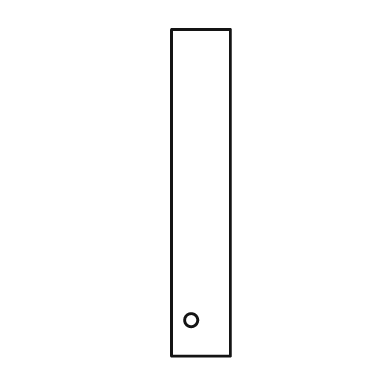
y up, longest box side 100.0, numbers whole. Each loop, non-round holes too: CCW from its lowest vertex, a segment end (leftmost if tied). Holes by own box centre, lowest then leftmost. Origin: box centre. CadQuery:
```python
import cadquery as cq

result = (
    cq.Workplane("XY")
    .moveTo(-9.0, -50.0)
    .lineTo(9.0, -50.0)
    .lineTo(9.0, 50.0)
    .lineTo(-9.0, 50.0)
    .close()
    .moveTo(-3.0, -39.0)
    .circle(2.0)
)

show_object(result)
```